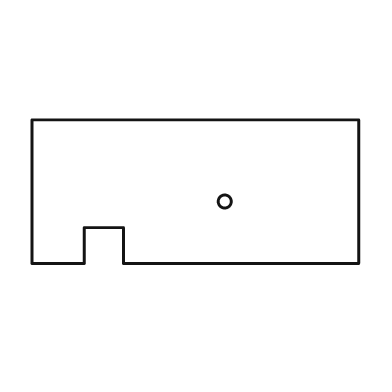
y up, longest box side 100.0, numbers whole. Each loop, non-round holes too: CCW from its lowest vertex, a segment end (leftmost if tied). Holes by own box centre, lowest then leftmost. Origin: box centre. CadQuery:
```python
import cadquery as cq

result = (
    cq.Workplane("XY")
    .moveTo(-50.0, -22.0)
    .lineTo(-34.0, -22.0)
    .lineTo(-34.0, -11.0)
    .lineTo(-22.0, -11.0)
    .lineTo(-22.0, -22.0)
    .lineTo(50.0, -22.0)
    .lineTo(50.0, 22.0)
    .lineTo(-50.0, 22.0)
    .close()
    .moveTo(9.0, -3.0)
    .circle(2.0)
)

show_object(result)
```